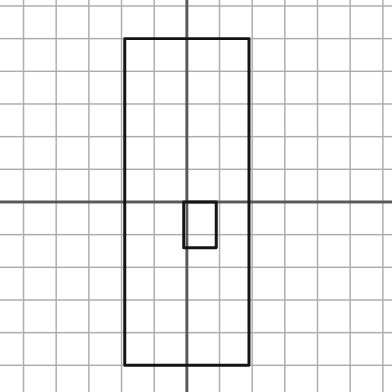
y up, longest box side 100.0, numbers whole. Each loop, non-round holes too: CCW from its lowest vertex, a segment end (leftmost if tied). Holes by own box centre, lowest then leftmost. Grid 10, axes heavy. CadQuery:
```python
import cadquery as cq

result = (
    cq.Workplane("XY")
    .moveTo(-19.0, -50.0)
    .lineTo(19.0, -50.0)
    .lineTo(19.0, 50.0)
    .lineTo(-19.0, 50.0)
    .close()
    .moveTo(-1.0, -14.0)
    .lineTo(9.0, -14.0)
    .lineTo(9.0, 0.0)
    .lineTo(-1.0, 0.0)
    .close()
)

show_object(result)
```